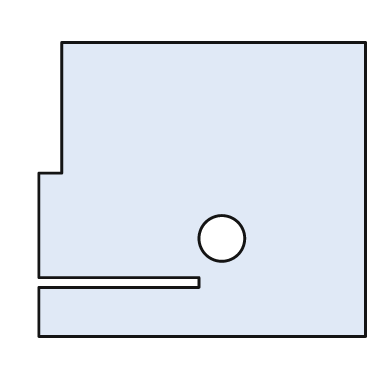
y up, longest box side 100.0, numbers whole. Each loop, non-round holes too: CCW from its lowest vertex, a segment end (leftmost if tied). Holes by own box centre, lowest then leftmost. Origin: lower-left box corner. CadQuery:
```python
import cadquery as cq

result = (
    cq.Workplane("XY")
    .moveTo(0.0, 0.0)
    .lineTo(100.0, 0.0)
    .lineTo(100.0, 90.0)
    .lineTo(7.0, 90.0)
    .lineTo(7.0, 50.0)
    .lineTo(0.0, 50.0)
    .lineTo(0.0, 18.0)
    .lineTo(49.0, 18.0)
    .lineTo(49.0, 15.0)
    .lineTo(0.0, 15.0)
    .close()
    .moveTo(56.0, 30.0)
    .circle(7.0)
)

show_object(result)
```